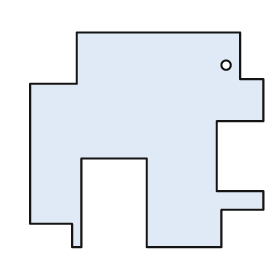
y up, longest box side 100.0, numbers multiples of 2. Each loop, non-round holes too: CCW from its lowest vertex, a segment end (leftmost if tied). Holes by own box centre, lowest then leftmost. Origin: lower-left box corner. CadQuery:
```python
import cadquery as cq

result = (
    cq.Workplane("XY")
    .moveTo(18.0, 0.0)
    .lineTo(22.0, 0.0)
    .lineTo(22.0, 38.0)
    .lineTo(50.0, 38.0)
    .lineTo(50.0, 0.0)
    .lineTo(82.0, 0.0)
    .lineTo(82.0, 16.0)
    .lineTo(100.0, 16.0)
    .lineTo(100.0, 24.0)
    .lineTo(80.0, 24.0)
    .lineTo(80.0, 54.0)
    .lineTo(100.0, 54.0)
    .lineTo(100.0, 72.0)
    .lineTo(90.0, 72.0)
    .lineTo(90.0, 92.0)
    .lineTo(20.0, 92.0)
    .lineTo(20.0, 70.0)
    .lineTo(0.0, 70.0)
    .lineTo(0.0, 10.0)
    .lineTo(18.0, 10.0)
    .close()
    .moveTo(84.0, 78.0)
    .circle(2.0)
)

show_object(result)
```